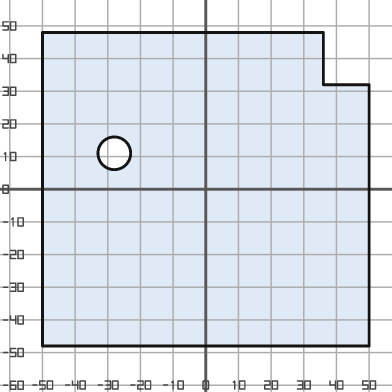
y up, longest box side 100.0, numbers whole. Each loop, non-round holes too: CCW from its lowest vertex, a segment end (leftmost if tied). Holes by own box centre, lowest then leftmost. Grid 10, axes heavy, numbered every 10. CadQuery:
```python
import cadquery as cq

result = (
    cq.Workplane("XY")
    .moveTo(-50.0, -48.0)
    .lineTo(50.0, -48.0)
    .lineTo(50.0, 32.0)
    .lineTo(36.0, 32.0)
    .lineTo(36.0, 48.0)
    .lineTo(-50.0, 48.0)
    .close()
    .moveTo(-28.0, 11.0)
    .circle(5.0)
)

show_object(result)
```